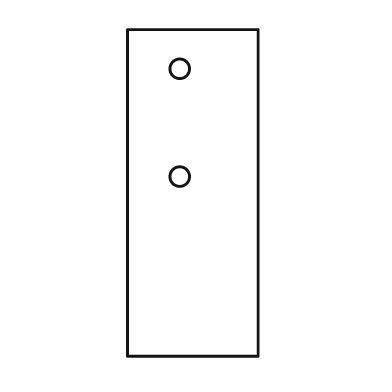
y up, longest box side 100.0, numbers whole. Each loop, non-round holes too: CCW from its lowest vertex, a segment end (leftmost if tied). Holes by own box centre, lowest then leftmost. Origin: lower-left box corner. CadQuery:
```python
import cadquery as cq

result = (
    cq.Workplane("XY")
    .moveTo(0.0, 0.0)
    .lineTo(40.0, 0.0)
    .lineTo(40.0, 100.0)
    .lineTo(0.0, 100.0)
    .close()
    .moveTo(16.0, 55.0)
    .circle(3.0)
    .moveTo(16.0, 88.0)
    .circle(3.0)
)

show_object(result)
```